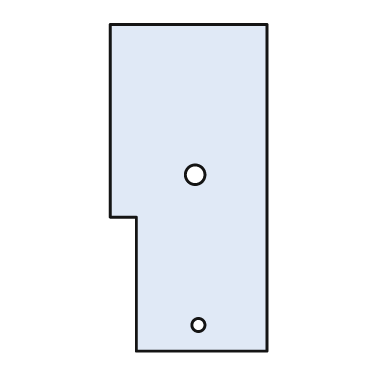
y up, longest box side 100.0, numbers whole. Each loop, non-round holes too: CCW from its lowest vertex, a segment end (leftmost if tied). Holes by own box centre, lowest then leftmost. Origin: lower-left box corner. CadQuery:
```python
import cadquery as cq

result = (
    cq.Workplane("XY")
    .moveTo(8.0, 0.0)
    .lineTo(48.0, 0.0)
    .lineTo(48.0, 100.0)
    .lineTo(0.0, 100.0)
    .lineTo(0.0, 41.0)
    .lineTo(8.0, 41.0)
    .close()
    .moveTo(27.0, 8.0)
    .circle(2.0)
    .moveTo(26.0, 54.0)
    .circle(3.0)
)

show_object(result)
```